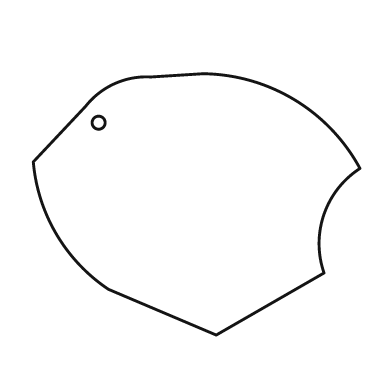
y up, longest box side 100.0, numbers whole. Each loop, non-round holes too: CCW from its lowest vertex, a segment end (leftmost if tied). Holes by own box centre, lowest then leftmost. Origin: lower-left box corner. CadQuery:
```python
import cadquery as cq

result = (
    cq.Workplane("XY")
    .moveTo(56.0, 0.0)
    .lineTo(89.0, 19.0)
    .threePointArc((89.0, 37.0), (100.0, 51.0))
    .threePointArc((80.0, 72.0), (52.0, 80.0))
    .lineTo(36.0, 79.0)
    .threePointArc((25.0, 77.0), (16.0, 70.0))
    .lineTo(0.0, 53.0)
    .threePointArc((7.0, 31.0), (23.0, 14.0))
    .close()
    .moveTo(20.0, 65.0)
    .circle(2.0)
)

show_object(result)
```